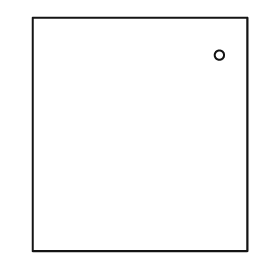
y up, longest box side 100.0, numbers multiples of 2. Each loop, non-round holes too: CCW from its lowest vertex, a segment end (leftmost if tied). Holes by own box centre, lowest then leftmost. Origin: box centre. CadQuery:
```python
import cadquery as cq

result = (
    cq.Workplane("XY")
    .moveTo(-46.0, -50.0)
    .lineTo(46.0, -50.0)
    .lineTo(46.0, 50.0)
    .lineTo(-46.0, 50.0)
    .close()
    .moveTo(34.0, 34.0)
    .circle(2.0)
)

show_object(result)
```